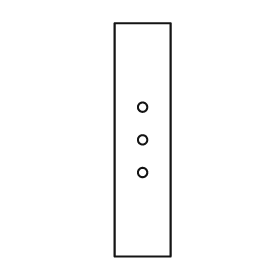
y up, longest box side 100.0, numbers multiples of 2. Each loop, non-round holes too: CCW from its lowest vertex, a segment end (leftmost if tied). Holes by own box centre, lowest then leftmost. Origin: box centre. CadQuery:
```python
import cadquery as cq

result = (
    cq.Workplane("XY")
    .moveTo(-12.0, -50.0)
    .lineTo(12.0, -50.0)
    .lineTo(12.0, 50.0)
    .lineTo(-12.0, 50.0)
    .close()
    .moveTo(0.0, -14.0)
    .circle(2.0)
    .moveTo(0.0, 0.0)
    .circle(2.0)
    .moveTo(0.0, 14.0)
    .circle(2.0)
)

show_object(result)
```